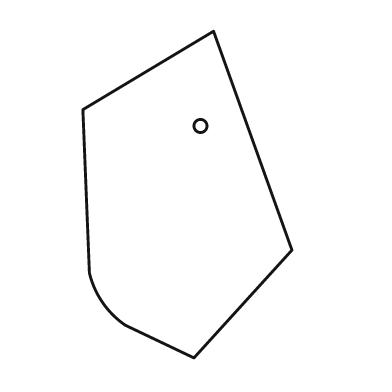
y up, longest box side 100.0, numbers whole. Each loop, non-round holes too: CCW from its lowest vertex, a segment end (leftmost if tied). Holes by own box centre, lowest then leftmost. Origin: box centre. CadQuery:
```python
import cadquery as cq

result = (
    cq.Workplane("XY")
    .moveTo(2.0, -50.0)
    .lineTo(32.0, -17.0)
    .lineTo(8.0, 50.0)
    .lineTo(-32.0, 26.0)
    .lineTo(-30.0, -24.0)
    .threePointArc((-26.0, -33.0), (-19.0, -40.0))
    .close()
    .moveTo(4.0, 21.0)
    .circle(2.0)
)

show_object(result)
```